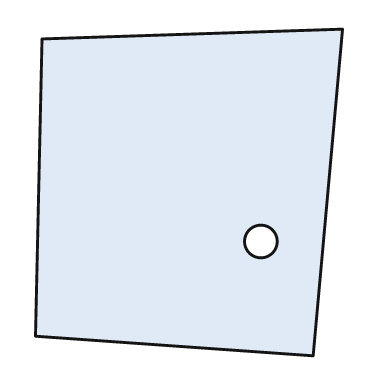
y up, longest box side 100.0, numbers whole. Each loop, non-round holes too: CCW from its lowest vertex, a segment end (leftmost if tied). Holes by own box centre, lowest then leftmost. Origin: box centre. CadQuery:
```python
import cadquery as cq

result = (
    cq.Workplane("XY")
    .moveTo(38.0, -50.0)
    .lineTo(47.0, 50.0)
    .lineTo(-45.0, 47.0)
    .lineTo(-47.0, -44.0)
    .close()
    .moveTo(22.0, -15.0)
    .circle(5.0)
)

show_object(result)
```